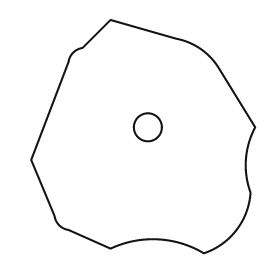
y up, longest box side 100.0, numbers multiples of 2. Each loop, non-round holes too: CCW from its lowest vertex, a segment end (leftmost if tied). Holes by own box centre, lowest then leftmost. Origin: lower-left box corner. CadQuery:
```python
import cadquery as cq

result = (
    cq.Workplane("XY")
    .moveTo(74.0, 0.0)
    .threePointArc((88.0, 10.0), (94.0, 26.0))
    .threePointArc((92.0, 40.0), (96.0, 54.0))
    .lineTo(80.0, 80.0)
    .threePointArc((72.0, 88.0), (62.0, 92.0))
    .lineTo(34.0, 100.0)
    .lineTo(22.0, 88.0)
    .threePointArc((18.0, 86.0), (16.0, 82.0))
    .lineTo(0.0, 40.0)
    .lineTo(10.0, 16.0)
    .threePointArc((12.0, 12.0), (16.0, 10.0))
    .lineTo(34.0, 2.0)
    .threePointArc((54.0, 6.0), (74.0, 0.0))
    .close()
    .moveTo(50.0, 54.0)
    .circle(6.0)
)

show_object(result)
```